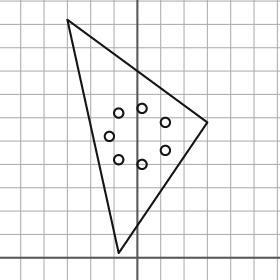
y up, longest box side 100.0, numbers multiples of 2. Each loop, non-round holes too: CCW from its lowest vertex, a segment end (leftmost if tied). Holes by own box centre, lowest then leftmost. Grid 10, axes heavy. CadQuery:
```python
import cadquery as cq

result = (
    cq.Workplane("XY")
    .moveTo(-8.0, 2.0)
    .lineTo(30.0, 58.0)
    .lineTo(-30.0, 102.0)
    .close()
    .moveTo(2.0, 40.0)
    .circle(2.0)
    .moveTo(-8.0, 42.0)
    .circle(2.0)
    .moveTo(12.0, 46.0)
    .circle(2.0)
    .moveTo(-12.0, 52.0)
    .circle(2.0)
    .moveTo(12.0, 58.0)
    .circle(2.0)
    .moveTo(-8.0, 62.0)
    .circle(2.0)
    .moveTo(2.0, 64.0)
    .circle(2.0)
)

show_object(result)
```